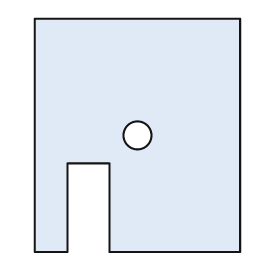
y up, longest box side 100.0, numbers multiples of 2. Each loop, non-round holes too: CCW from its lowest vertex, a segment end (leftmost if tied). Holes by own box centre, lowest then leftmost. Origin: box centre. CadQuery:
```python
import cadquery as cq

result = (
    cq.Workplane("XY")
    .moveTo(-44.0, -50.0)
    .lineTo(-30.0, -50.0)
    .lineTo(-30.0, -12.0)
    .lineTo(-12.0, -12.0)
    .lineTo(-12.0, -50.0)
    .lineTo(44.0, -50.0)
    .lineTo(44.0, 50.0)
    .lineTo(-44.0, 50.0)
    .close()
    .moveTo(0.0, 0.0)
    .circle(6.0)
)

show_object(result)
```